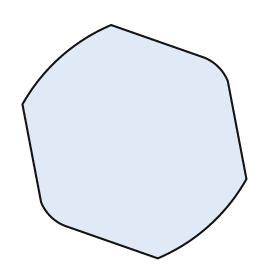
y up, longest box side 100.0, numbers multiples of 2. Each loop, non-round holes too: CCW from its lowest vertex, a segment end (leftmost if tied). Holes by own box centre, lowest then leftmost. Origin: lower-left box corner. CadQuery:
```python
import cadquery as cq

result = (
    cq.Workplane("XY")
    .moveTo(58.0, 0.0)
    .threePointArc((80.0, 14.0), (96.0, 34.0))
    .lineTo(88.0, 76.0)
    .threePointArc((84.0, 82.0), (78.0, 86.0))
    .lineTo(38.0, 100.0)
    .threePointArc((16.0, 86.0), (0.0, 66.0))
    .lineTo(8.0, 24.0)
    .threePointArc((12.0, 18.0), (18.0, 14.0))
    .close()
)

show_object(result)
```